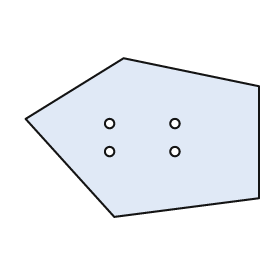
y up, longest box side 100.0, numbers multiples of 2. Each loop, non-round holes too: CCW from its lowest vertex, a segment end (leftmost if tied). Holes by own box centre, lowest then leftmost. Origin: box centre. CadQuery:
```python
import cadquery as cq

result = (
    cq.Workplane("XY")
    .moveTo(-12.0, -34.0)
    .lineTo(50.0, -26.0)
    .lineTo(50.0, 22.0)
    .lineTo(-8.0, 34.0)
    .lineTo(-50.0, 8.0)
    .close()
    .moveTo(-14.0, -6.0)
    .circle(2.0)
    .moveTo(14.0, -6.0)
    .circle(2.0)
    .moveTo(-14.0, 6.0)
    .circle(2.0)
    .moveTo(14.0, 6.0)
    .circle(2.0)
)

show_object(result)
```